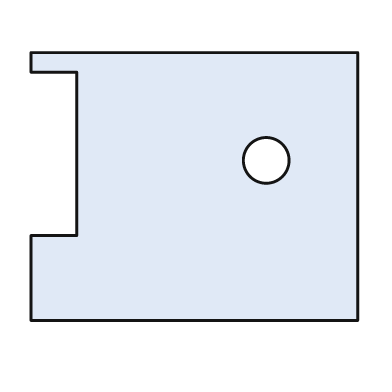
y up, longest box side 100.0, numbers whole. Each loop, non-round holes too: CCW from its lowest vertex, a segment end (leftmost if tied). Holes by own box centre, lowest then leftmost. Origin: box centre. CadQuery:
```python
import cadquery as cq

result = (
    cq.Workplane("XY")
    .moveTo(-50.0, -41.0)
    .lineTo(50.0, -41.0)
    .lineTo(50.0, 41.0)
    .lineTo(-50.0, 41.0)
    .lineTo(-50.0, 35.0)
    .lineTo(-36.0, 35.0)
    .lineTo(-36.0, -15.0)
    .lineTo(-50.0, -15.0)
    .close()
    .moveTo(22.0, 8.0)
    .circle(7.0)
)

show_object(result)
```